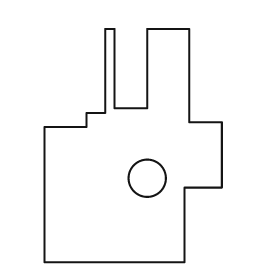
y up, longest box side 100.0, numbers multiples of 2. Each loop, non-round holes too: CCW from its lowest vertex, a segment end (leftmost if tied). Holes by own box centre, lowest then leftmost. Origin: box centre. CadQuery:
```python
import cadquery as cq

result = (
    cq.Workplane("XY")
    .moveTo(-38.0, -50.0)
    .lineTo(22.0, -50.0)
    .lineTo(22.0, -18.0)
    .lineTo(38.0, -18.0)
    .lineTo(38.0, 10.0)
    .lineTo(24.0, 10.0)
    .lineTo(24.0, 50.0)
    .lineTo(6.0, 50.0)
    .lineTo(6.0, 16.0)
    .lineTo(-8.0, 16.0)
    .lineTo(-8.0, 50.0)
    .lineTo(-12.0, 50.0)
    .lineTo(-12.0, 14.0)
    .lineTo(-20.0, 14.0)
    .lineTo(-20.0, 8.0)
    .lineTo(-38.0, 8.0)
    .close()
    .moveTo(6.0, -14.0)
    .circle(8.0)
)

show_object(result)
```